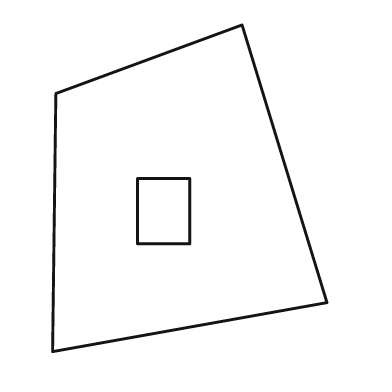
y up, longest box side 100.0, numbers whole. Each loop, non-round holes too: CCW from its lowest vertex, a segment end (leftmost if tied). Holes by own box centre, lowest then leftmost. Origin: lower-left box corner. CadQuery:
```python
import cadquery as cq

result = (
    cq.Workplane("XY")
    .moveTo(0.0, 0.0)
    .lineTo(84.0, 15.0)
    .lineTo(58.0, 100.0)
    .lineTo(1.0, 79.0)
    .close()
    .moveTo(26.0, 33.0)
    .lineTo(42.0, 33.0)
    .lineTo(42.0, 53.0)
    .lineTo(26.0, 53.0)
    .close()
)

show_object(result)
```